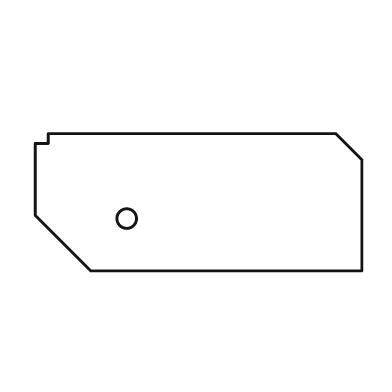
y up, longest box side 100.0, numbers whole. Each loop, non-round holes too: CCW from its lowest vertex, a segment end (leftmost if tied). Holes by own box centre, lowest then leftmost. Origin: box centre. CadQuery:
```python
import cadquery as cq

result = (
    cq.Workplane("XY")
    .moveTo(-33.0, -21.0)
    .lineTo(50.0, -21.0)
    .lineTo(50.0, 13.0)
    .lineTo(42.0, 21.0)
    .lineTo(-46.0, 21.0)
    .lineTo(-46.0, 18.0)
    .lineTo(-50.0, 18.0)
    .lineTo(-50.0, -4.0)
    .close()
    .moveTo(-22.0, -5.0)
    .circle(3.0)
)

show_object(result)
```